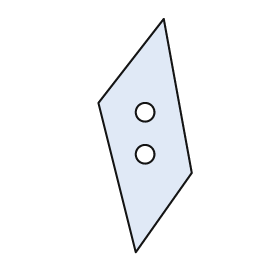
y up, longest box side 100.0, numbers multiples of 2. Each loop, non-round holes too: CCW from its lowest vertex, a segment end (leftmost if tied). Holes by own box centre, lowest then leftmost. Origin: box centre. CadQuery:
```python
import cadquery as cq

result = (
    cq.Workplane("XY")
    .moveTo(-4.0, -50.0)
    .lineTo(20.0, -16.0)
    .lineTo(8.0, 50.0)
    .lineTo(-20.0, 14.0)
    .close()
    .moveTo(0.0, -8.0)
    .circle(4.0)
    .moveTo(0.0, 10.0)
    .circle(4.0)
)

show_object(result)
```